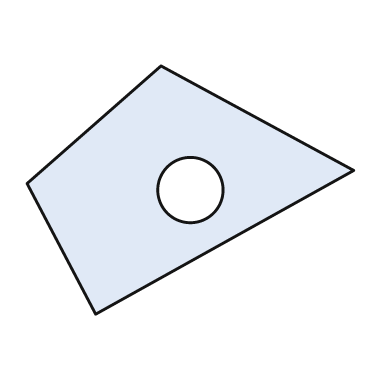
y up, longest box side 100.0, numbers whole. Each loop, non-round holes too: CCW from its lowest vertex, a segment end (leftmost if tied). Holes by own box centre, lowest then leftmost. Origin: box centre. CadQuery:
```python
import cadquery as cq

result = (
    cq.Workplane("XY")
    .moveTo(-29.0, -38.0)
    .lineTo(50.0, 6.0)
    .lineTo(-9.0, 38.0)
    .lineTo(-50.0, 2.0)
    .close()
    .moveTo(0.0, 0.0)
    .circle(10.0)
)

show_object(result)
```